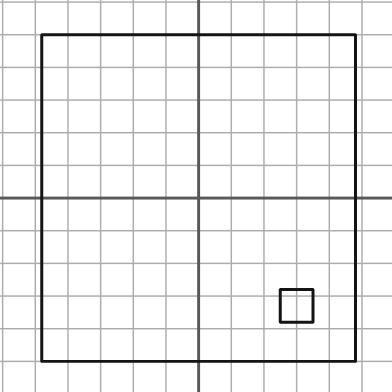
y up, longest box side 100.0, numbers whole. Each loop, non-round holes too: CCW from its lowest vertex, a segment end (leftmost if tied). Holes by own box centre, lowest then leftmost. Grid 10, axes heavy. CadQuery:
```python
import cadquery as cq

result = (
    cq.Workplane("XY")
    .moveTo(-48.0, -50.0)
    .lineTo(48.0, -50.0)
    .lineTo(48.0, 50.0)
    .lineTo(-48.0, 50.0)
    .close()
    .moveTo(25.0, -38.0)
    .lineTo(35.0, -38.0)
    .lineTo(35.0, -28.0)
    .lineTo(25.0, -28.0)
    .close()
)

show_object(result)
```